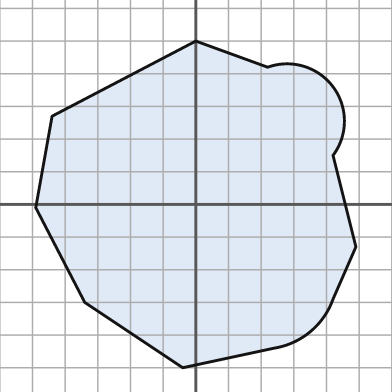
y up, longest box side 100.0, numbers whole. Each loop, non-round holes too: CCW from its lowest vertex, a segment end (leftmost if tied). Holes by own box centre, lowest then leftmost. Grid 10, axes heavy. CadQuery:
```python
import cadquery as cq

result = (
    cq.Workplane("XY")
    .moveTo(-4.0, -50.0)
    .lineTo(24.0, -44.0)
    .threePointArc((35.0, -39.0), (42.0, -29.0))
    .lineTo(49.0, -13.0)
    .lineTo(42.0, 15.0)
    .threePointArc((42.0, 36.0), (22.0, 42.0))
    .lineTo(0.0, 50.0)
    .lineTo(-44.0, 27.0)
    .lineTo(-49.0, -1.0)
    .lineTo(-34.0, -30.0)
    .close()
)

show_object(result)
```